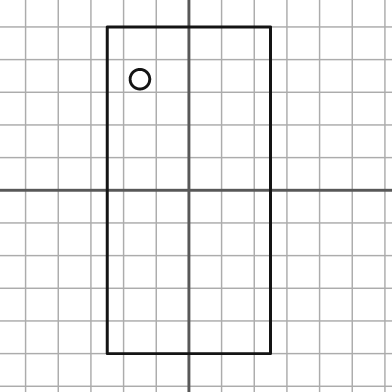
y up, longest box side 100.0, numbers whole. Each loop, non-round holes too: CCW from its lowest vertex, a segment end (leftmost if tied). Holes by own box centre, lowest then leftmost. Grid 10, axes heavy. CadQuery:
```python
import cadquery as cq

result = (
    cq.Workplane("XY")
    .moveTo(-25.0, -50.0)
    .lineTo(25.0, -50.0)
    .lineTo(25.0, 50.0)
    .lineTo(-25.0, 50.0)
    .close()
    .moveTo(-15.0, 34.0)
    .circle(3.0)
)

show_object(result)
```